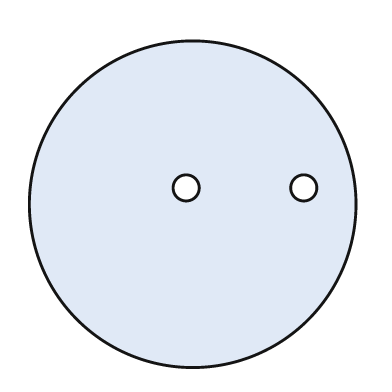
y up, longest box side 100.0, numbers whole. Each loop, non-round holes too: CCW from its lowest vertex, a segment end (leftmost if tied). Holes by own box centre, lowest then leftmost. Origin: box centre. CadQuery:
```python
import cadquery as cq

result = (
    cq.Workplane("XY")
    .moveTo(0.0, 0.0)
    .circle(50.0)
    .moveTo(-2.0, 5.0)
    .circle(4.0)
    .moveTo(34.0, 5.0)
    .circle(4.0)
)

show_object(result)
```